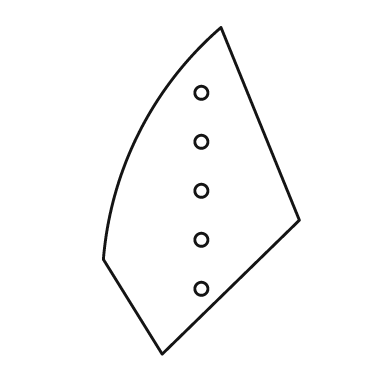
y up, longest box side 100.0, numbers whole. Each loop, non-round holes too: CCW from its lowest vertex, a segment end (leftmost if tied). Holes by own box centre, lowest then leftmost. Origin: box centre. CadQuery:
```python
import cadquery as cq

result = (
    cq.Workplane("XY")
    .moveTo(-12.0, -50.0)
    .lineTo(30.0, -9.0)
    .lineTo(6.0, 50.0)
    .threePointArc((-19.0, 18.0), (-30.0, -21.0))
    .close()
    .moveTo(0.0, -30.0)
    .circle(2.0)
    .moveTo(0.0, -15.0)
    .circle(2.0)
    .moveTo(0.0, 0.0)
    .circle(2.0)
    .moveTo(0.0, 15.0)
    .circle(2.0)
    .moveTo(0.0, 30.0)
    .circle(2.0)
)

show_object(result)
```